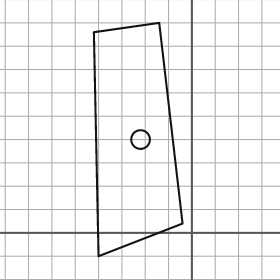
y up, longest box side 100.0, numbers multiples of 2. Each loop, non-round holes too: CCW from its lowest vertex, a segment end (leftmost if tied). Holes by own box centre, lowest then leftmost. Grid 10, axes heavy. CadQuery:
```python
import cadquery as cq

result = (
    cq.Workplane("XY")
    .moveTo(-40.0, -10.0)
    .lineTo(-4.0, 4.0)
    .lineTo(-14.0, 90.0)
    .lineTo(-42.0, 86.0)
    .close()
    .moveTo(-22.0, 40.0)
    .circle(4.0)
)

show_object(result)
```